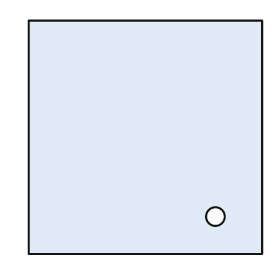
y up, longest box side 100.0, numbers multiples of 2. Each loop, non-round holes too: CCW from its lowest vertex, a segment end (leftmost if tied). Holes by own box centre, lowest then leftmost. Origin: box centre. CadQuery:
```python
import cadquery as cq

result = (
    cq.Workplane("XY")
    .moveTo(-50.0, -50.0)
    .lineTo(50.0, -50.0)
    .lineTo(50.0, 50.0)
    .lineTo(-50.0, 50.0)
    .close()
    .moveTo(30.0, -34.0)
    .circle(4.0)
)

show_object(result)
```